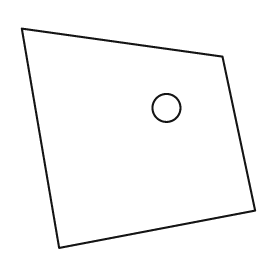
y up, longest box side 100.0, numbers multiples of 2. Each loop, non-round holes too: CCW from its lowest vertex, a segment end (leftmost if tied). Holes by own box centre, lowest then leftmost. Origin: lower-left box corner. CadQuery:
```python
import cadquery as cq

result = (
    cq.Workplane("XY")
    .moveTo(16.0, 0.0)
    .lineTo(100.0, 16.0)
    .lineTo(86.0, 82.0)
    .lineTo(0.0, 94.0)
    .close()
    .moveTo(62.0, 60.0)
    .circle(6.0)
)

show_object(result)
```